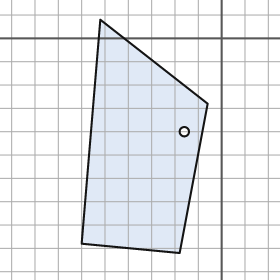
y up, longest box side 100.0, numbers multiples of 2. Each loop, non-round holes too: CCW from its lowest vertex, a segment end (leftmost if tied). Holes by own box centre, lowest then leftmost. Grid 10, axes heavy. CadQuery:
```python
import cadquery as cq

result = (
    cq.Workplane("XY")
    .moveTo(-18.0, -92.0)
    .lineTo(-6.0, -28.0)
    .lineTo(-52.0, 8.0)
    .lineTo(-60.0, -88.0)
    .close()
    .moveTo(-16.0, -40.0)
    .circle(2.0)
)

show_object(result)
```